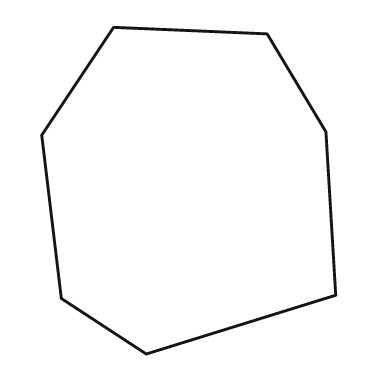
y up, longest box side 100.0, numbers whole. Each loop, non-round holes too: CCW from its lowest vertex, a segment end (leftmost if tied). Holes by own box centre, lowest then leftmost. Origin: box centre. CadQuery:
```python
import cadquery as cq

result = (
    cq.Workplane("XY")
    .moveTo(-13.0, -50.0)
    .lineTo(45.0, -32.0)
    .lineTo(42.0, 18.0)
    .lineTo(24.0, 48.0)
    .lineTo(-23.0, 50.0)
    .lineTo(-45.0, 17.0)
    .lineTo(-39.0, -33.0)
    .close()
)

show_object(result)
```